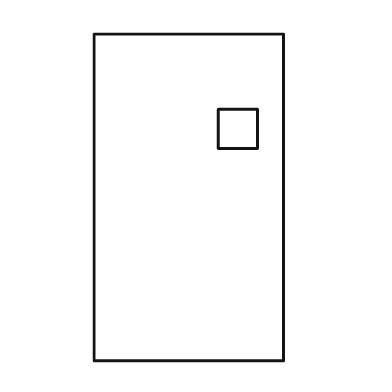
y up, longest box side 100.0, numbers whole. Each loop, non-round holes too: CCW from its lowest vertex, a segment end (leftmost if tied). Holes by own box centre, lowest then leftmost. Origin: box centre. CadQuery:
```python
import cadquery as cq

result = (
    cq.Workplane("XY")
    .moveTo(-29.0, -50.0)
    .lineTo(29.0, -50.0)
    .lineTo(29.0, 50.0)
    .lineTo(-29.0, 50.0)
    .close()
    .moveTo(9.0, 15.0)
    .lineTo(21.0, 15.0)
    .lineTo(21.0, 27.0)
    .lineTo(9.0, 27.0)
    .close()
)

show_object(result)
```